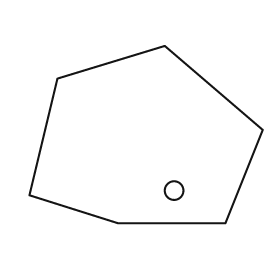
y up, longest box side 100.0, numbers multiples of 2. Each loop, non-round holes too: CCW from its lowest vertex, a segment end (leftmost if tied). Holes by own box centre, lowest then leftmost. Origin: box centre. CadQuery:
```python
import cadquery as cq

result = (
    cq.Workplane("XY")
    .moveTo(-12.0, -38.0)
    .lineTo(34.0, -38.0)
    .lineTo(50.0, 2.0)
    .lineTo(8.0, 38.0)
    .lineTo(-38.0, 24.0)
    .lineTo(-50.0, -26.0)
    .close()
    .moveTo(12.0, -24.0)
    .circle(4.0)
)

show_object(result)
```